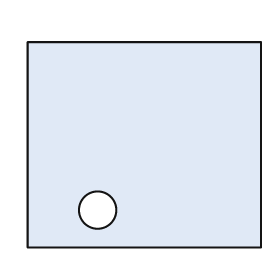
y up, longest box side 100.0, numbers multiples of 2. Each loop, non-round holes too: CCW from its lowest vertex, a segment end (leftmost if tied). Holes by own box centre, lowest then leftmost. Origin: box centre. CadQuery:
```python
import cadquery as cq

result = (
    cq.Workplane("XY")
    .moveTo(-50.0, -44.0)
    .lineTo(50.0, -44.0)
    .lineTo(50.0, 44.0)
    .lineTo(-50.0, 44.0)
    .close()
    .moveTo(-20.0, -28.0)
    .circle(8.0)
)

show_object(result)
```